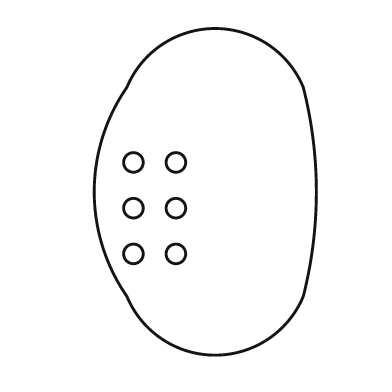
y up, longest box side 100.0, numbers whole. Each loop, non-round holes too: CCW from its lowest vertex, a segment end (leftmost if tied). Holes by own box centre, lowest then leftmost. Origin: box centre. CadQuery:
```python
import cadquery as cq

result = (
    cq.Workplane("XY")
    .moveTo(-24.0, -32.0)
    .threePointArc((3.0, -50.0), (30.0, -32.0))
    .threePointArc((34.0, 0.0), (30.0, 32.0))
    .threePointArc((3.0, 50.0), (-24.0, 32.0))
    .threePointArc((-34.0, 0.0), (-24.0, -32.0))
    .close()
    .moveTo(-22.0, -19.0)
    .circle(3.0)
    .moveTo(-9.0, -19.0)
    .circle(3.0)
    .moveTo(-22.0, -5.0)
    .circle(3.0)
    .moveTo(-9.0, -5.0)
    .circle(3.0)
    .moveTo(-22.0, 9.0)
    .circle(3.0)
    .moveTo(-9.0, 9.0)
    .circle(3.0)
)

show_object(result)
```